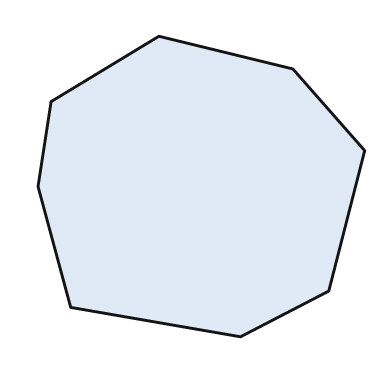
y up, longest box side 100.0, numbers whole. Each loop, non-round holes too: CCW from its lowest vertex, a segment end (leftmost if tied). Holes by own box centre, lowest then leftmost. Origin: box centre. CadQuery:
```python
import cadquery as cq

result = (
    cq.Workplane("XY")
    .moveTo(12.0, -46.0)
    .lineTo(39.0, -32.0)
    .lineTo(50.0, 11.0)
    .lineTo(28.0, 36.0)
    .lineTo(-13.0, 46.0)
    .lineTo(-46.0, 26.0)
    .lineTo(-50.0, 0.0)
    .lineTo(-40.0, -37.0)
    .close()
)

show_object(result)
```